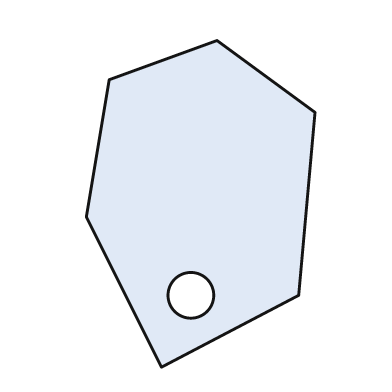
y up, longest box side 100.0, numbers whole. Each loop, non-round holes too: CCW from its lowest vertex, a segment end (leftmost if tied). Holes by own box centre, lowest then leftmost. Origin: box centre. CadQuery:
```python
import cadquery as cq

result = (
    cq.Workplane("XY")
    .moveTo(-12.0, -50.0)
    .lineTo(30.0, -28.0)
    .lineTo(35.0, 28.0)
    .lineTo(5.0, 50.0)
    .lineTo(-28.0, 38.0)
    .lineTo(-35.0, -4.0)
    .close()
    .moveTo(-3.0, -28.0)
    .circle(7.0)
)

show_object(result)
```